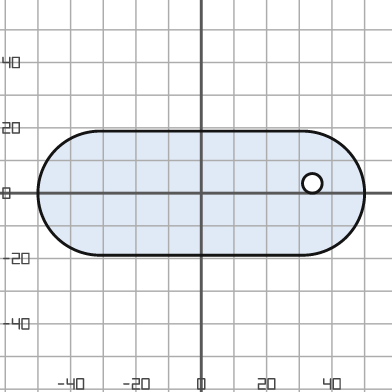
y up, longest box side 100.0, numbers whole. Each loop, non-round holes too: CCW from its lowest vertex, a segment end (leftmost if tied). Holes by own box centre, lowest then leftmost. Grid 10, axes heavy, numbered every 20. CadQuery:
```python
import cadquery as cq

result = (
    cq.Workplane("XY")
    .moveTo(-31.0, -19.0)
    .lineTo(31.0, -19.0)
    .threePointArc((50.0, 0.0), (31.0, 19.0))
    .lineTo(-31.0, 19.0)
    .threePointArc((-50.0, 0.0), (-31.0, -19.0))
    .close()
    .moveTo(34.0, 3.0)
    .circle(3.0)
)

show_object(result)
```